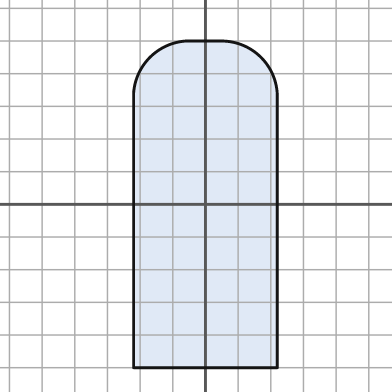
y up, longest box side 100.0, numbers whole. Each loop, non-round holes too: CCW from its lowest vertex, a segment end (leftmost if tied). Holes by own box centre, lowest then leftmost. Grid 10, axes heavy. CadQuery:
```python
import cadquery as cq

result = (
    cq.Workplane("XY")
    .moveTo(-22.0, -50.0)
    .lineTo(22.0, -50.0)
    .lineTo(22.0, 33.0)
    .threePointArc((17.0, 45.0), (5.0, 50.0))
    .lineTo(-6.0, 50.0)
    .threePointArc((-17.0, 45.0), (-22.0, 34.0))
    .close()
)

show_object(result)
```